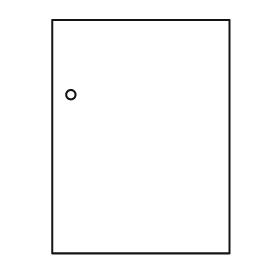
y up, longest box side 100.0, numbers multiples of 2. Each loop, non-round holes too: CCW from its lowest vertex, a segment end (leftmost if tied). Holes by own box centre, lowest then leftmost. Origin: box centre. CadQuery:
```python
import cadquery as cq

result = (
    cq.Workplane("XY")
    .moveTo(-38.0, -50.0)
    .lineTo(38.0, -50.0)
    .lineTo(38.0, 50.0)
    .lineTo(-38.0, 50.0)
    .close()
    .moveTo(-30.0, 18.0)
    .circle(2.0)
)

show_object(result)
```